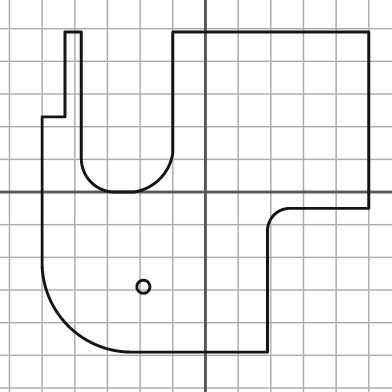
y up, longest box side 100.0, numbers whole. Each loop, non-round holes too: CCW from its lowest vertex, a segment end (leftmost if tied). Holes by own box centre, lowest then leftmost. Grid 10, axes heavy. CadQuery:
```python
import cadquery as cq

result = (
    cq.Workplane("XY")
    .moveTo(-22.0, -49.0)
    .lineTo(19.0, -49.0)
    .lineTo(19.0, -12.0)
    .threePointArc((21.0, -7.0), (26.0, -5.0))
    .lineTo(50.0, -5.0)
    .lineTo(50.0, 49.0)
    .lineTo(-10.0, 49.0)
    .lineTo(-10.0, 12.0)
    .threePointArc((-14.0, 4.0), (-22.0, 0.0))
    .lineTo(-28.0, 0.0)
    .threePointArc((-35.0, 3.0), (-38.0, 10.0))
    .lineTo(-38.0, 49.0)
    .lineTo(-43.0, 49.0)
    .lineTo(-43.0, 23.0)
    .lineTo(-50.0, 23.0)
    .lineTo(-50.0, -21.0)
    .threePointArc((-42.0, -41.0), (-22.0, -49.0))
    .close()
    .moveTo(-19.0, -29.0)
    .circle(2.0)
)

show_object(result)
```